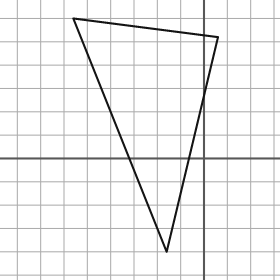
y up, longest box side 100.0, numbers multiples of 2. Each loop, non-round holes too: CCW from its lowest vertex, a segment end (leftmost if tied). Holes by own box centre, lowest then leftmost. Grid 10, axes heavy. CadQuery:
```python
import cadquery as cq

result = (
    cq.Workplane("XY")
    .moveTo(-16.0, -40.0)
    .lineTo(6.0, 52.0)
    .lineTo(-56.0, 60.0)
    .close()
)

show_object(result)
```